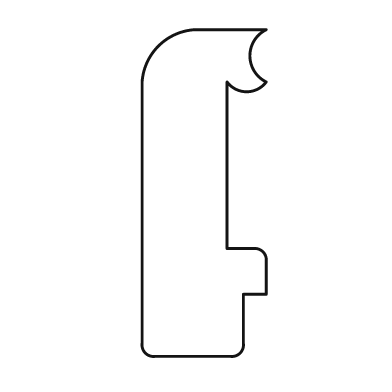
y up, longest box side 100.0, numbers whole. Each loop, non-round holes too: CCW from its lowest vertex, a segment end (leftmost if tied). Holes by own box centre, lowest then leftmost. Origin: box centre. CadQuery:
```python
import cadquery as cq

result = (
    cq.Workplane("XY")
    .moveTo(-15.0, -50.0)
    .lineTo(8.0, -50.0)
    .threePointArc((11.0, -49.0), (12.0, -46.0))
    .lineTo(12.0, -31.0)
    .lineTo(19.0, -31.0)
    .lineTo(19.0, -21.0)
    .threePointArc((18.0, -18.0), (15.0, -17.0))
    .lineTo(7.0, -17.0)
    .lineTo(7.0, 34.0)
    .threePointArc((13.0, 31.0), (19.0, 34.0))
    .threePointArc((14.0, 42.0), (19.0, 50.0))
    .lineTo(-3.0, 50.0)
    .threePointArc((-14.0, 45.0), (-19.0, 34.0))
    .lineTo(-19.0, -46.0)
    .threePointArc((-18.0, -49.0), (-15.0, -50.0))
    .close()
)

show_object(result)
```